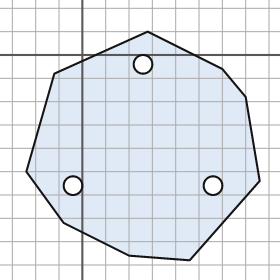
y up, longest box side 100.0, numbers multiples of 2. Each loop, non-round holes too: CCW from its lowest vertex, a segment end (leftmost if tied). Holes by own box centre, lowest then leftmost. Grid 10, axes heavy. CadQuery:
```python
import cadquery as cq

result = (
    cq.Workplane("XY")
    .moveTo(46.0, -88.0)
    .lineTo(76.0, -54.0)
    .lineTo(70.0, -18.0)
    .lineTo(60.0, -6.0)
    .lineTo(28.0, 10.0)
    .lineTo(-12.0, -8.0)
    .lineTo(-24.0, -50.0)
    .lineTo(-8.0, -72.0)
    .lineTo(20.0, -86.0)
    .close()
    .moveTo(-4.0, -56.0)
    .circle(4.0)
    .moveTo(56.0, -56.0)
    .circle(4.0)
    .moveTo(26.0, -4.0)
    .circle(4.0)
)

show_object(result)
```